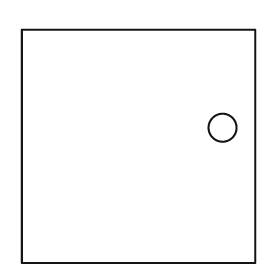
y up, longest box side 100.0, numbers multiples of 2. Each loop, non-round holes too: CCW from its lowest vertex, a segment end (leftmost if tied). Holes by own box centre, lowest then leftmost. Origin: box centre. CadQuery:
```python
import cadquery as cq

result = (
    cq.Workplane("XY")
    .moveTo(-50.0, -50.0)
    .lineTo(50.0, -50.0)
    .lineTo(50.0, 50.0)
    .lineTo(-50.0, 50.0)
    .close()
    .moveTo(36.0, 8.0)
    .circle(6.0)
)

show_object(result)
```